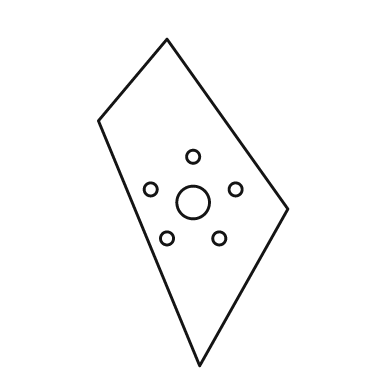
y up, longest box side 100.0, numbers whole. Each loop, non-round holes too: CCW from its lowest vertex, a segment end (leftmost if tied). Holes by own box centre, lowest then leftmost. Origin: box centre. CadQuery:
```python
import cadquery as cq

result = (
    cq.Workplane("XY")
    .moveTo(2.0, -50.0)
    .lineTo(29.0, -2.0)
    .lineTo(-8.0, 50.0)
    .lineTo(-29.0, 25.0)
    .close()
    .moveTo(-8.0, -11.0)
    .circle(2.0)
    .moveTo(8.0, -11.0)
    .circle(2.0)
    .moveTo(0.0, 0.0)
    .circle(5.0)
    .moveTo(-13.0, 4.0)
    .circle(2.0)
    .moveTo(13.0, 4.0)
    .circle(2.0)
    .moveTo(0.0, 14.0)
    .circle(2.0)
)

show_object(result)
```